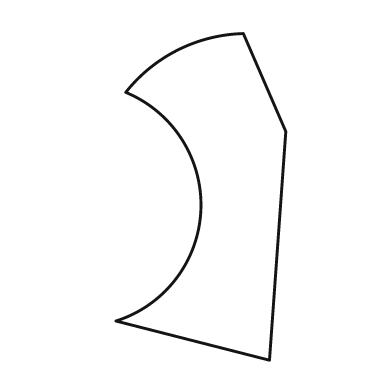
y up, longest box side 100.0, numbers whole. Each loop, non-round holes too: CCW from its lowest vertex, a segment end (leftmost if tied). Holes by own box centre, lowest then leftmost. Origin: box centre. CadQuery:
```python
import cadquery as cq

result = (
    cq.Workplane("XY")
    .moveTo(21.0, -50.0)
    .lineTo(26.0, 20.0)
    .lineTo(13.0, 50.0)
    .threePointArc((-7.0, 45.0), (-23.0, 32.0))
    .threePointArc((0.0, -4.0), (-26.0, -38.0))
    .close()
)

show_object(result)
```